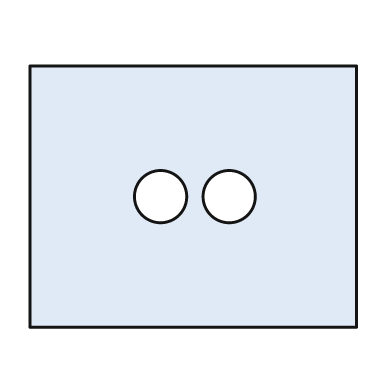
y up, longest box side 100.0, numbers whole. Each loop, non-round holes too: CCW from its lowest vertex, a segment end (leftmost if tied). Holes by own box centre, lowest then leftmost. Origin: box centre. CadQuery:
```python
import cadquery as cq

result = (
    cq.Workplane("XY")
    .moveTo(-50.0, -40.0)
    .lineTo(50.0, -40.0)
    .lineTo(50.0, 40.0)
    .lineTo(-50.0, 40.0)
    .close()
    .moveTo(-10.0, 0.0)
    .circle(8.0)
    .moveTo(11.0, 0.0)
    .circle(8.0)
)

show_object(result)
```